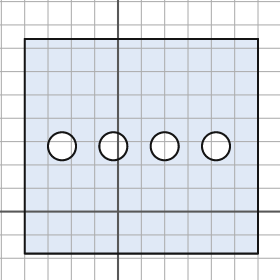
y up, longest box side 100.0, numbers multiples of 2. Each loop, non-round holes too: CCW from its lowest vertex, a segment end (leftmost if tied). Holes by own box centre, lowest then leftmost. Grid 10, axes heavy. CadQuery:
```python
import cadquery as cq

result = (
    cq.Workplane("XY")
    .moveTo(-40.0, -18.0)
    .lineTo(60.0, -18.0)
    .lineTo(60.0, 74.0)
    .lineTo(-40.0, 74.0)
    .close()
    .moveTo(-24.0, 28.0)
    .circle(6.0)
    .moveTo(-2.0, 28.0)
    .circle(6.0)
    .moveTo(20.0, 28.0)
    .circle(6.0)
    .moveTo(42.0, 28.0)
    .circle(6.0)
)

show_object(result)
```